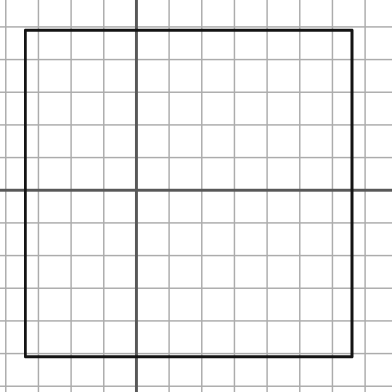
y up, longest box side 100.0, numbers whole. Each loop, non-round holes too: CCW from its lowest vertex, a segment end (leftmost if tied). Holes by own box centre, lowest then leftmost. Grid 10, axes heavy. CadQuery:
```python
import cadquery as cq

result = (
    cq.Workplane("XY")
    .moveTo(-34.0, -51.0)
    .lineTo(66.0, -51.0)
    .lineTo(66.0, 49.0)
    .lineTo(-34.0, 49.0)
    .close()
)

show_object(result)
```